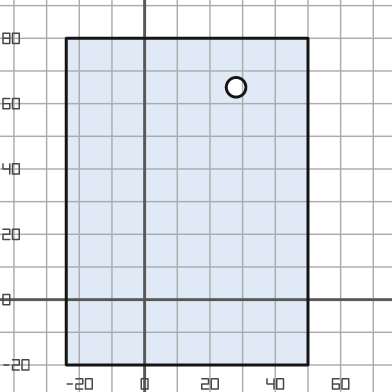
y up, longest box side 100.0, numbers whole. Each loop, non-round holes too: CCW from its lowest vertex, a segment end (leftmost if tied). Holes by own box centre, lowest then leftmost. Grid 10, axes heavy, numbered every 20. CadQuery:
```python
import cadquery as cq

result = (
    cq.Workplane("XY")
    .moveTo(-24.0, -20.0)
    .lineTo(50.0, -20.0)
    .lineTo(50.0, 80.0)
    .lineTo(-24.0, 80.0)
    .close()
    .moveTo(28.0, 65.0)
    .circle(3.0)
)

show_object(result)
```